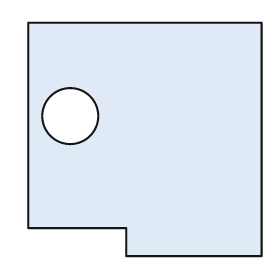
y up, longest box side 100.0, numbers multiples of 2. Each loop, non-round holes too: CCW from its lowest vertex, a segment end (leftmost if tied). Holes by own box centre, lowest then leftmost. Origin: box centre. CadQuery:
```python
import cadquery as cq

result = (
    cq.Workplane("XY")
    .moveTo(-8.0, -50.0)
    .lineTo(50.0, -50.0)
    .lineTo(50.0, 50.0)
    .lineTo(-50.0, 50.0)
    .lineTo(-50.0, -38.0)
    .lineTo(-8.0, -38.0)
    .close()
    .moveTo(-32.0, 10.0)
    .circle(12.0)
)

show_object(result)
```